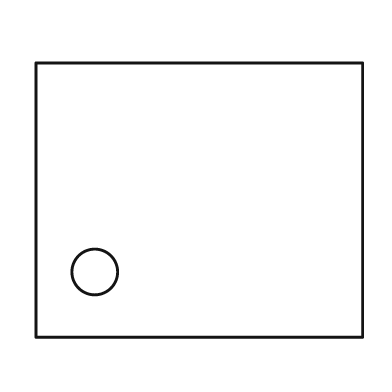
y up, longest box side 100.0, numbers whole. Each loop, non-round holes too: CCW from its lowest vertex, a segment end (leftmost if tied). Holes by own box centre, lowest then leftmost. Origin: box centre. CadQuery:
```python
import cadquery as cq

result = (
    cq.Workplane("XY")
    .moveTo(-50.0, -42.0)
    .lineTo(50.0, -42.0)
    .lineTo(50.0, 42.0)
    .lineTo(-50.0, 42.0)
    .close()
    .moveTo(-32.0, -22.0)
    .circle(7.0)
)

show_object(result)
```